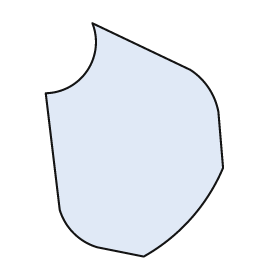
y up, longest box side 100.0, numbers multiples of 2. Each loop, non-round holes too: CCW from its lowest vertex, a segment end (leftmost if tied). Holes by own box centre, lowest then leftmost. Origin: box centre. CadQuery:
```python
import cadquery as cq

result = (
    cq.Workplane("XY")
    .moveTo(4.0, -50.0)
    .threePointArc((24.0, -34.0), (38.0, -12.0))
    .lineTo(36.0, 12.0)
    .threePointArc((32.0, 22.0), (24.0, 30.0))
    .lineTo(-18.0, 50.0)
    .threePointArc((-20.0, 30.0), (-38.0, 20.0))
    .lineTo(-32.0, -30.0)
    .threePointArc((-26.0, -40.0), (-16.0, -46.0))
    .close()
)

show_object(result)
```